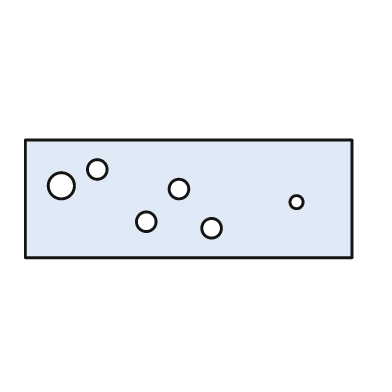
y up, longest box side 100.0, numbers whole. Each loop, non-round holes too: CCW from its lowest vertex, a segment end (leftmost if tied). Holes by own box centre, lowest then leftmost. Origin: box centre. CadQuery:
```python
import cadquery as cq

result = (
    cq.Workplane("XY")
    .moveTo(-50.0, -18.0)
    .lineTo(50.0, -18.0)
    .lineTo(50.0, 18.0)
    .lineTo(-50.0, 18.0)
    .close()
    .moveTo(7.0, -9.0)
    .circle(3.0)
    .moveTo(-13.0, -7.0)
    .circle(3.0)
    .moveTo(33.0, -1.0)
    .circle(2.0)
    .moveTo(-3.0, 3.0)
    .circle(3.0)
    .moveTo(-39.0, 4.0)
    .circle(4.0)
    .moveTo(-28.0, 9.0)
    .circle(3.0)
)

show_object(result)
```